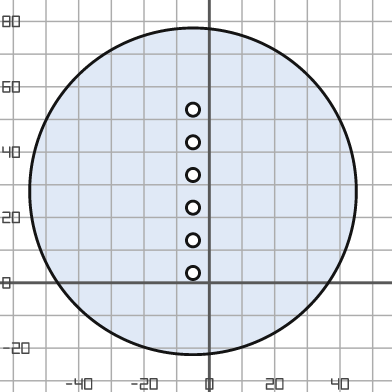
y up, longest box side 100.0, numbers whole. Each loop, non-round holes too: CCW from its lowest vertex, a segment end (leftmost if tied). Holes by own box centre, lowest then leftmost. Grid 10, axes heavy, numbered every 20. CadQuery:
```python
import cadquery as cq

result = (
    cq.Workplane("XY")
    .moveTo(-5.0, 28.0)
    .circle(50.0)
    .moveTo(-5.0, 3.0)
    .circle(2.0)
    .moveTo(-5.0, 13.0)
    .circle(2.0)
    .moveTo(-5.0, 23.0)
    .circle(2.0)
    .moveTo(-5.0, 33.0)
    .circle(2.0)
    .moveTo(-5.0, 43.0)
    .circle(2.0)
    .moveTo(-5.0, 53.0)
    .circle(2.0)
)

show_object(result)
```